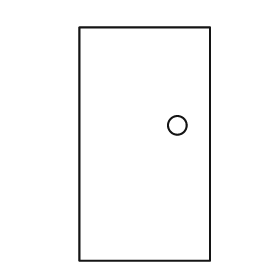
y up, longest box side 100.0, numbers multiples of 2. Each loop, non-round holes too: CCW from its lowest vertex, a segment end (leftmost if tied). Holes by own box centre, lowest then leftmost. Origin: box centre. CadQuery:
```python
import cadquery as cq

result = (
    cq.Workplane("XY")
    .moveTo(-28.0, -50.0)
    .lineTo(28.0, -50.0)
    .lineTo(28.0, 50.0)
    .lineTo(-28.0, 50.0)
    .close()
    .moveTo(14.0, 8.0)
    .circle(4.0)
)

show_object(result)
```